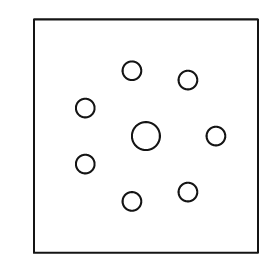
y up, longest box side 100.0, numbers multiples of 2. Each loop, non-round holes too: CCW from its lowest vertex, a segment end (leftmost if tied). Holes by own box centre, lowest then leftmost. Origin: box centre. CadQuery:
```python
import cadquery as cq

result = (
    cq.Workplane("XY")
    .moveTo(-48.0, -50.0)
    .lineTo(48.0, -50.0)
    .lineTo(48.0, 50.0)
    .lineTo(-48.0, 50.0)
    .close()
    .moveTo(-6.0, -28.0)
    .circle(4.0)
    .moveTo(18.0, -24.0)
    .circle(4.0)
    .moveTo(-26.0, -12.0)
    .circle(4.0)
    .moveTo(0.0, 0.0)
    .circle(6.0)
    .moveTo(30.0, 0.0)
    .circle(4.0)
    .moveTo(-26.0, 12.0)
    .circle(4.0)
    .moveTo(18.0, 24.0)
    .circle(4.0)
    .moveTo(-6.0, 28.0)
    .circle(4.0)
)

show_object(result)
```